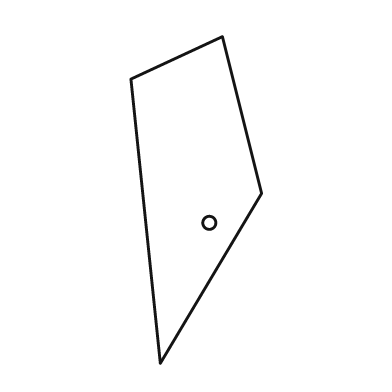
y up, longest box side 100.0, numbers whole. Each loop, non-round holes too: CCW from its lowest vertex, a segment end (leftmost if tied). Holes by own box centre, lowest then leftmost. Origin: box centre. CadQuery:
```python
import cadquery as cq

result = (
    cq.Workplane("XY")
    .moveTo(-11.0, -50.0)
    .lineTo(20.0, 2.0)
    .lineTo(8.0, 50.0)
    .lineTo(-20.0, 37.0)
    .close()
    .moveTo(4.0, -7.0)
    .circle(2.0)
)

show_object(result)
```